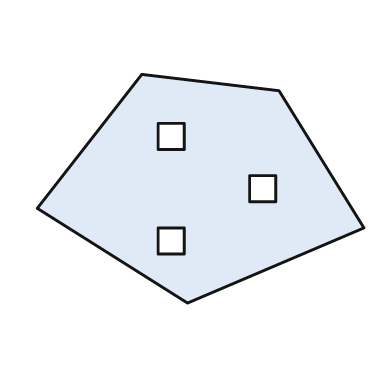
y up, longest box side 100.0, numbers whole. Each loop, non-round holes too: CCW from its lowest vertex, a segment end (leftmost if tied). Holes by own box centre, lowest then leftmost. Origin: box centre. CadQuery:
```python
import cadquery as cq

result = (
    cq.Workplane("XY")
    .moveTo(-4.0, -35.0)
    .lineTo(50.0, -12.0)
    .lineTo(24.0, 30.0)
    .lineTo(-18.0, 35.0)
    .lineTo(-50.0, -6.0)
    .close()
    .moveTo(-13.0, -20.0)
    .lineTo(-5.0, -20.0)
    .lineTo(-5.0, -12.0)
    .lineTo(-13.0, -12.0)
    .close()
    .moveTo(15.0, -4.0)
    .lineTo(23.0, -4.0)
    .lineTo(23.0, 4.0)
    .lineTo(15.0, 4.0)
    .close()
    .moveTo(-13.0, 12.0)
    .lineTo(-5.0, 12.0)
    .lineTo(-5.0, 20.0)
    .lineTo(-13.0, 20.0)
    .close()
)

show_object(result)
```